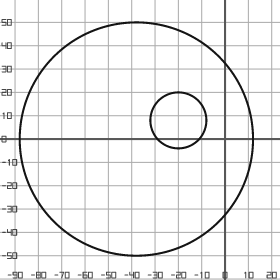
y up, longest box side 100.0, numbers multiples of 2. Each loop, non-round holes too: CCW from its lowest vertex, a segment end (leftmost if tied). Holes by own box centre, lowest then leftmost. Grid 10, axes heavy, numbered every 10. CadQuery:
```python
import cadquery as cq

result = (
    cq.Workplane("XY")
    .moveTo(-38.0, 0.0)
    .circle(50.0)
    .moveTo(-20.0, 8.0)
    .circle(12.0)
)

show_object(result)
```